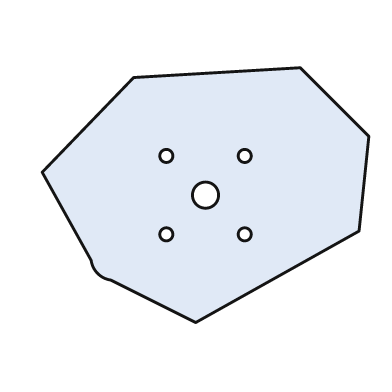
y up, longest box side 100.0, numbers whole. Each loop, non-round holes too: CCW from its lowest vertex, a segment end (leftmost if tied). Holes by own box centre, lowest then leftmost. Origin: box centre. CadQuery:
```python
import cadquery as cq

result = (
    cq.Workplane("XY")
    .moveTo(-3.0, -39.0)
    .lineTo(47.0, -11.0)
    .lineTo(50.0, 18.0)
    .lineTo(29.0, 39.0)
    .lineTo(-22.0, 36.0)
    .lineTo(-50.0, 7.0)
    .lineTo(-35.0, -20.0)
    .threePointArc((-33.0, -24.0), (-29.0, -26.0))
    .close()
    .moveTo(-12.0, -12.0)
    .circle(2.0)
    .moveTo(12.0, -12.0)
    .circle(2.0)
    .moveTo(0.0, 0.0)
    .circle(4.0)
    .moveTo(-12.0, 12.0)
    .circle(2.0)
    .moveTo(12.0, 12.0)
    .circle(2.0)
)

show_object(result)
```